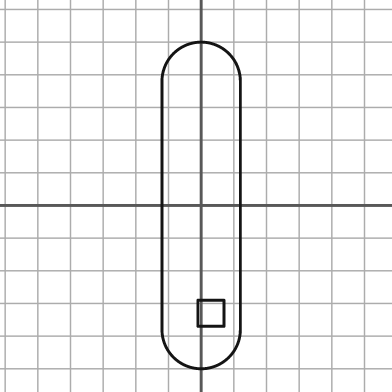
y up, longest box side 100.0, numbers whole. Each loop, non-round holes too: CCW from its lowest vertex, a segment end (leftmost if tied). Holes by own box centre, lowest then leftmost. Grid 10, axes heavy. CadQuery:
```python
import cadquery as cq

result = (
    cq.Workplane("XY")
    .moveTo(-12.0, -38.0)
    .threePointArc((0.0, -50.0), (12.0, -38.0))
    .lineTo(12.0, 38.0)
    .threePointArc((0.0, 50.0), (-12.0, 38.0))
    .close()
    .moveTo(-1.0, -37.0)
    .lineTo(7.0, -37.0)
    .lineTo(7.0, -29.0)
    .lineTo(-1.0, -29.0)
    .close()
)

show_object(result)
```